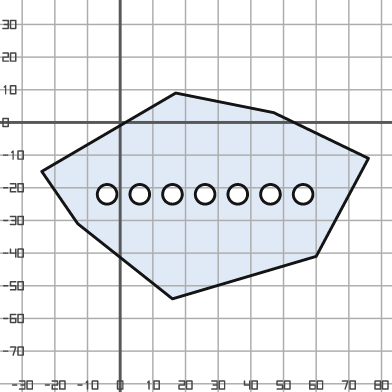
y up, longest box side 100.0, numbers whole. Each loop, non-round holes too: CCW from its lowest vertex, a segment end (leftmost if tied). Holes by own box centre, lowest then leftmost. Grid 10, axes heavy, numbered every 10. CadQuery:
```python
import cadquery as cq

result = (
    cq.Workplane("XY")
    .moveTo(16.0, -54.0)
    .lineTo(60.0, -41.0)
    .lineTo(76.0, -11.0)
    .lineTo(47.0, 3.0)
    .lineTo(17.0, 9.0)
    .lineTo(-24.0, -15.0)
    .lineTo(-13.0, -31.0)
    .close()
    .moveTo(-4.0, -22.0)
    .circle(3.0)
    .moveTo(6.0, -22.0)
    .circle(3.0)
    .moveTo(16.0, -22.0)
    .circle(3.0)
    .moveTo(26.0, -22.0)
    .circle(3.0)
    .moveTo(36.0, -22.0)
    .circle(3.0)
    .moveTo(46.0, -22.0)
    .circle(3.0)
    .moveTo(56.0, -22.0)
    .circle(3.0)
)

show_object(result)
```